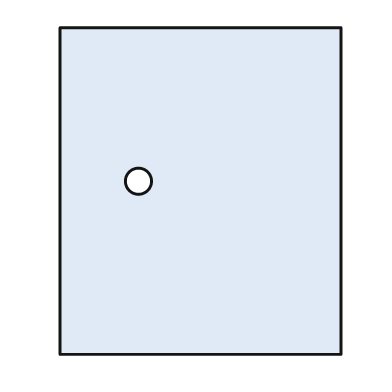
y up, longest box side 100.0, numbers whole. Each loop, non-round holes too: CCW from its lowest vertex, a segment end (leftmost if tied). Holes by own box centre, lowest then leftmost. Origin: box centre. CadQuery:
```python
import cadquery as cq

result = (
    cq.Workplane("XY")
    .moveTo(-43.0, -50.0)
    .lineTo(43.0, -50.0)
    .lineTo(43.0, 50.0)
    .lineTo(-43.0, 50.0)
    .close()
    .moveTo(-19.0, 3.0)
    .circle(4.0)
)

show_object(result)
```